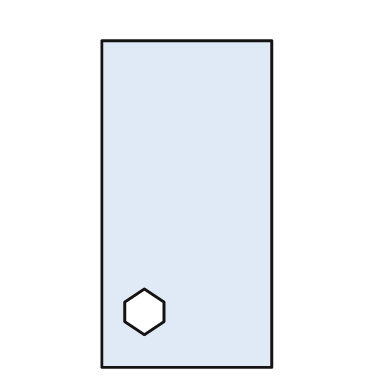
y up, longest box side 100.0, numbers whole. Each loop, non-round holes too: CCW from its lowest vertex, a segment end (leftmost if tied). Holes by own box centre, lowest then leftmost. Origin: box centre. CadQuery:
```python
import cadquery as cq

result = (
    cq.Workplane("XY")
    .moveTo(-26.0, -50.0)
    .lineTo(26.0, -50.0)
    .lineTo(26.0, 50.0)
    .lineTo(-26.0, 50.0)
    .close()
    .moveTo(-13.0, -40.0)
    .lineTo(-7.0, -36.0)
    .lineTo(-7.0, -30.0)
    .lineTo(-13.0, -26.0)
    .lineTo(-19.0, -30.0)
    .lineTo(-19.0, -36.0)
    .close()
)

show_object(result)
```